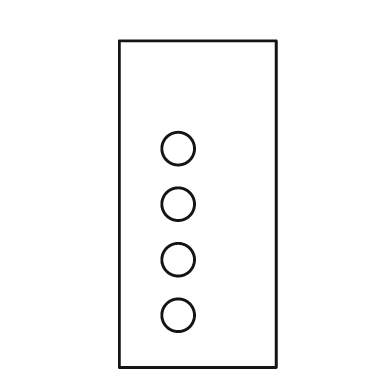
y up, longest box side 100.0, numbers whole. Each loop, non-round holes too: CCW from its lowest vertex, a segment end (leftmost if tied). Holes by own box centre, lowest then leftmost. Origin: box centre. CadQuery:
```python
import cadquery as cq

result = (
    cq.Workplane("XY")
    .moveTo(-24.0, -50.0)
    .lineTo(24.0, -50.0)
    .lineTo(24.0, 50.0)
    .lineTo(-24.0, 50.0)
    .close()
    .moveTo(-6.0, -34.0)
    .circle(5.0)
    .moveTo(-6.0, -17.0)
    .circle(5.0)
    .moveTo(-6.0, 0.0)
    .circle(5.0)
    .moveTo(-6.0, 17.0)
    .circle(5.0)
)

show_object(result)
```